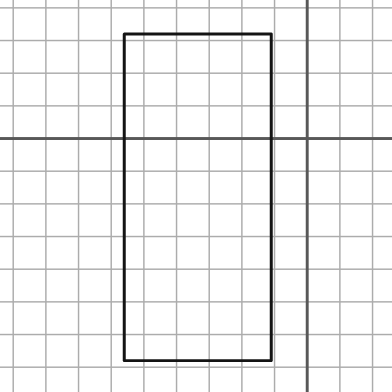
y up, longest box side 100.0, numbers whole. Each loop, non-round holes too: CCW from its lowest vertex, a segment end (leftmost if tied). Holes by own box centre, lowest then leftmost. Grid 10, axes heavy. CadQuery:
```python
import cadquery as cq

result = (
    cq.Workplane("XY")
    .moveTo(-56.0, -68.0)
    .lineTo(-11.0, -68.0)
    .lineTo(-11.0, 32.0)
    .lineTo(-56.0, 32.0)
    .close()
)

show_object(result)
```